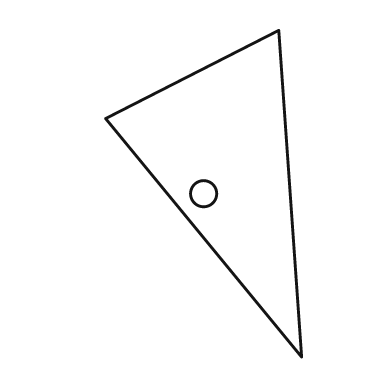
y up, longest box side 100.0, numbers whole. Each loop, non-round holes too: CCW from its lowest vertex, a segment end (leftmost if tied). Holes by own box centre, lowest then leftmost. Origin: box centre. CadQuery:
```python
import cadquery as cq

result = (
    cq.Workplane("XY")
    .moveTo(30.0, -50.0)
    .lineTo(23.0, 50.0)
    .lineTo(-30.0, 23.0)
    .close()
    .moveTo(0.0, 0.0)
    .circle(4.0)
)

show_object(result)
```